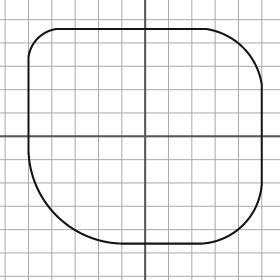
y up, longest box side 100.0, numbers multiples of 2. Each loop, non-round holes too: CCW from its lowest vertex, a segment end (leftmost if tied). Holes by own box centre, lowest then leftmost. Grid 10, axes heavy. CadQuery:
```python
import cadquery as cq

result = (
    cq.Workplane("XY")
    .moveTo(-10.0, -46.0)
    .lineTo(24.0, -46.0)
    .threePointArc((42.0, -38.0), (50.0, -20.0))
    .lineTo(50.0, 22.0)
    .threePointArc((42.0, 38.0), (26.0, 46.0))
    .lineTo(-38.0, 46.0)
    .threePointArc((-46.0, 42.0), (-50.0, 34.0))
    .lineTo(-50.0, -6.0)
    .threePointArc((-38.0, -34.0), (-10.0, -46.0))
    .close()
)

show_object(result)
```